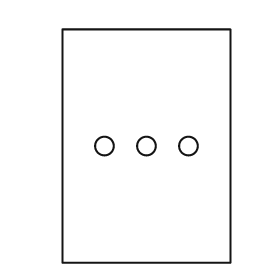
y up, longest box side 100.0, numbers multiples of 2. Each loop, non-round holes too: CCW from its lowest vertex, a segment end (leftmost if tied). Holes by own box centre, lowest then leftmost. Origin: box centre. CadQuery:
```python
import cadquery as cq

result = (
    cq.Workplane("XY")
    .moveTo(-36.0, -50.0)
    .lineTo(36.0, -50.0)
    .lineTo(36.0, 50.0)
    .lineTo(-36.0, 50.0)
    .close()
    .moveTo(-18.0, 0.0)
    .circle(4.0)
    .moveTo(0.0, 0.0)
    .circle(4.0)
    .moveTo(18.0, 0.0)
    .circle(4.0)
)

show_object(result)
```